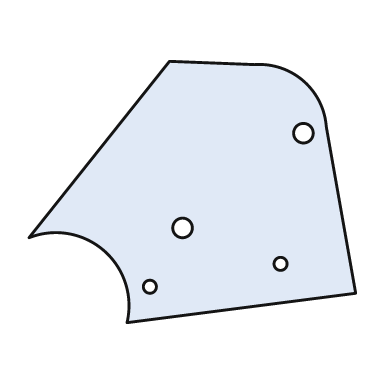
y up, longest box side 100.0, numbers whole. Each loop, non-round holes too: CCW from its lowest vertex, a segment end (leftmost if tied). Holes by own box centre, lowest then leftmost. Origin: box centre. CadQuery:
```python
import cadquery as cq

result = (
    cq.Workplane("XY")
    .moveTo(-20.0, -40.0)
    .lineTo(50.0, -31.0)
    .lineTo(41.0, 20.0)
    .threePointArc((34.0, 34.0), (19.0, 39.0))
    .lineTo(-7.0, 40.0)
    .lineTo(-50.0, -14.0)
    .threePointArc((-27.0, -18.0), (-20.0, -40.0))
    .close()
    .moveTo(-13.0, -29.0)
    .circle(2.0)
    .moveTo(27.0, -22.0)
    .circle(2.0)
    .moveTo(-3.0, -11.0)
    .circle(3.0)
    .moveTo(34.0, 18.0)
    .circle(3.0)
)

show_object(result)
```